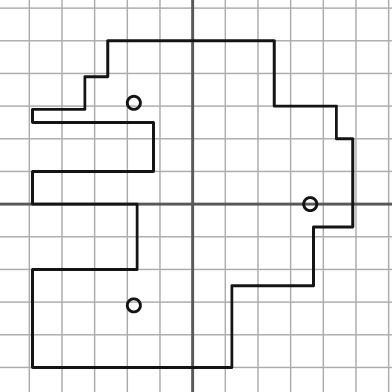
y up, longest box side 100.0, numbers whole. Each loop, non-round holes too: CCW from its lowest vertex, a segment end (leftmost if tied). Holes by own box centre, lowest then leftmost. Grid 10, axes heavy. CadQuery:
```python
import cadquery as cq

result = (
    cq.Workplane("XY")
    .moveTo(-49.0, -50.0)
    .lineTo(12.0, -50.0)
    .lineTo(12.0, -25.0)
    .lineTo(37.0, -25.0)
    .lineTo(37.0, -7.0)
    .lineTo(49.0, -7.0)
    .lineTo(49.0, 20.0)
    .lineTo(44.0, 20.0)
    .lineTo(44.0, 30.0)
    .lineTo(25.0, 30.0)
    .lineTo(25.0, 50.0)
    .lineTo(-26.0, 50.0)
    .lineTo(-26.0, 39.0)
    .lineTo(-33.0, 39.0)
    .lineTo(-33.0, 29.0)
    .lineTo(-49.0, 29.0)
    .lineTo(-49.0, 25.0)
    .lineTo(-12.0, 25.0)
    .lineTo(-12.0, 10.0)
    .lineTo(-49.0, 10.0)
    .lineTo(-49.0, 0.0)
    .lineTo(-17.0, 0.0)
    .lineTo(-17.0, -20.0)
    .lineTo(-49.0, -20.0)
    .close()
    .moveTo(-18.0, -31.0)
    .circle(2.0)
    .moveTo(36.0, 0.0)
    .circle(2.0)
    .moveTo(-18.0, 31.0)
    .circle(2.0)
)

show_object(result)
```